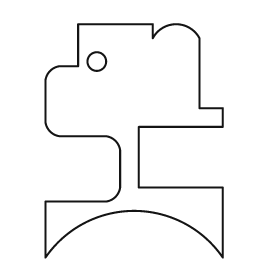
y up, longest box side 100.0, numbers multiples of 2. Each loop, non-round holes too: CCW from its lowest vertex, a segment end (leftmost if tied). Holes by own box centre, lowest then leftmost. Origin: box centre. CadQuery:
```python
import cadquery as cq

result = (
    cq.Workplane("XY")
    .moveTo(-38.0, -50.0)
    .threePointArc((0.0, -30.0), (38.0, -50.0))
    .lineTo(38.0, -20.0)
    .lineTo(2.0, -20.0)
    .lineTo(2.0, 6.0)
    .lineTo(38.0, 6.0)
    .lineTo(38.0, 14.0)
    .lineTo(28.0, 14.0)
    .lineTo(28.0, 44.0)
    .threePointArc((18.0, 50.0), (8.0, 44.0))
    .lineTo(8.0, 50.0)
    .lineTo(-24.0, 50.0)
    .lineTo(-24.0, 32.0)
    .lineTo(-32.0, 32.0)
    .threePointArc((-36.0, 30.0), (-38.0, 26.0))
    .lineTo(-38.0, 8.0)
    .threePointArc((-36.0, 4.0), (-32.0, 2.0))
    .lineTo(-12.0, 2.0)
    .threePointArc((-8.0, 0.0), (-6.0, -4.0))
    .lineTo(-6.0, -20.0)
    .threePointArc((-8.0, -24.0), (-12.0, -26.0))
    .lineTo(-38.0, -26.0)
    .close()
    .moveTo(-16.0, 34.0)
    .circle(4.0)
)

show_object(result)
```